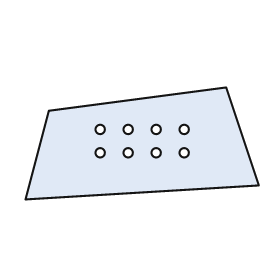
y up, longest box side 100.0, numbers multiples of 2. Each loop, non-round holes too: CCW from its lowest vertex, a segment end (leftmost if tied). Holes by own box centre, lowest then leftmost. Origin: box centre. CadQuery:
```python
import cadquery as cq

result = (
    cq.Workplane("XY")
    .moveTo(-50.0, -24.0)
    .lineTo(50.0, -18.0)
    .lineTo(36.0, 24.0)
    .lineTo(-40.0, 14.0)
    .close()
    .moveTo(-18.0, -4.0)
    .circle(2.0)
    .moveTo(-6.0, -4.0)
    .circle(2.0)
    .moveTo(6.0, -4.0)
    .circle(2.0)
    .moveTo(18.0, -4.0)
    .circle(2.0)
    .moveTo(-18.0, 6.0)
    .circle(2.0)
    .moveTo(-6.0, 6.0)
    .circle(2.0)
    .moveTo(6.0, 6.0)
    .circle(2.0)
    .moveTo(18.0, 6.0)
    .circle(2.0)
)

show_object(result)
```